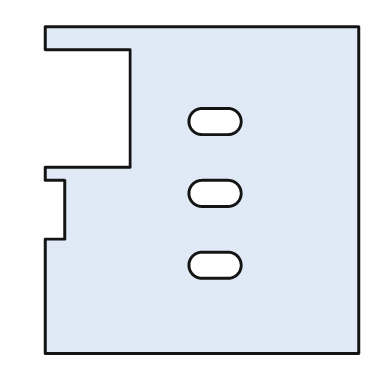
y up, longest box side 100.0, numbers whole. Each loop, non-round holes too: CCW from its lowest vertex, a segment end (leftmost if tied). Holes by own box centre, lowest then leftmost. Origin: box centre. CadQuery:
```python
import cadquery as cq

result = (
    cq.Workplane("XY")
    .moveTo(-48.0, -50.0)
    .lineTo(48.0, -50.0)
    .lineTo(48.0, 50.0)
    .lineTo(-48.0, 50.0)
    .lineTo(-48.0, 43.0)
    .lineTo(-22.0, 43.0)
    .lineTo(-22.0, 7.0)
    .lineTo(-48.0, 7.0)
    .lineTo(-48.0, 3.0)
    .lineTo(-42.0, 3.0)
    .lineTo(-42.0, -15.0)
    .lineTo(-48.0, -15.0)
    .close()
    .moveTo(0.0, -27.0)
    .lineTo(8.0, -27.0)
    .threePointArc((12.0, -23.0), (8.0, -19.0))
    .lineTo(0.0, -19.0)
    .threePointArc((-4.0, -23.0), (0.0, -27.0))
    .close()
    .moveTo(0.0, -5.0)
    .lineTo(8.0, -5.0)
    .threePointArc((12.0, -1.0), (8.0, 3.0))
    .lineTo(0.0, 3.0)
    .threePointArc((-4.0, -1.0), (0.0, -5.0))
    .close()
    .moveTo(0.0, 17.0)
    .lineTo(8.0, 17.0)
    .threePointArc((12.0, 21.0), (8.0, 25.0))
    .lineTo(0.0, 25.0)
    .threePointArc((-4.0, 21.0), (0.0, 17.0))
    .close()
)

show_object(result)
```